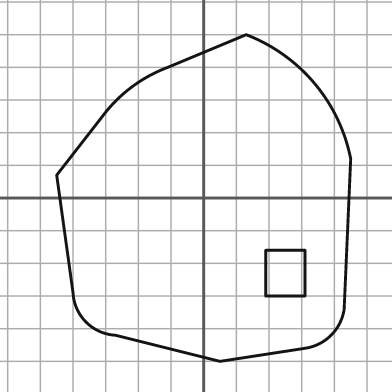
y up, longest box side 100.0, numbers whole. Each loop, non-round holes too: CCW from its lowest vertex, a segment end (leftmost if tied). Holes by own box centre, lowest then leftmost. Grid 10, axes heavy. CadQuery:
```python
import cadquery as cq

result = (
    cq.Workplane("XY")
    .moveTo(5.0, -50.0)
    .lineTo(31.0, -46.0)
    .threePointArc((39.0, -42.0), (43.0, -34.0))
    .lineTo(45.0, 12.0)
    .threePointArc((34.0, 35.0), (13.0, 50.0))
    .lineTo(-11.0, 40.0)
    .threePointArc((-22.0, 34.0), (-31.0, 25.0))
    .lineTo(-45.0, 7.0)
    .lineTo(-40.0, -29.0)
    .threePointArc((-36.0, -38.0), (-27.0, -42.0))
    .close()
    .moveTo(19.0, -30.0)
    .lineTo(31.0, -30.0)
    .lineTo(31.0, -16.0)
    .lineTo(19.0, -16.0)
    .close()
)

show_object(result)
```